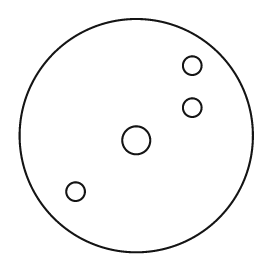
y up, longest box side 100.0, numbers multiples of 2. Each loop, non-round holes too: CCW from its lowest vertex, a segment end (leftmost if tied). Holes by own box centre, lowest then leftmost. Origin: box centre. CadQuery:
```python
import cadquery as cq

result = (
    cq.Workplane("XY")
    .moveTo(0.0, 0.0)
    .circle(50.0)
    .moveTo(-26.0, -24.0)
    .circle(4.0)
    .moveTo(0.0, -2.0)
    .circle(6.0)
    .moveTo(24.0, 12.0)
    .circle(4.0)
    .moveTo(24.0, 30.0)
    .circle(4.0)
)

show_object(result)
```